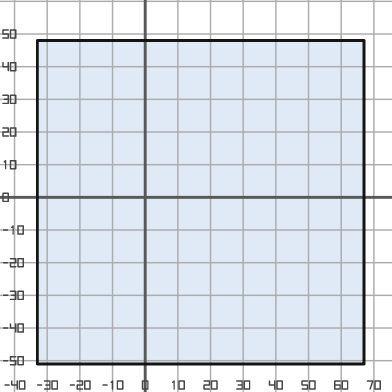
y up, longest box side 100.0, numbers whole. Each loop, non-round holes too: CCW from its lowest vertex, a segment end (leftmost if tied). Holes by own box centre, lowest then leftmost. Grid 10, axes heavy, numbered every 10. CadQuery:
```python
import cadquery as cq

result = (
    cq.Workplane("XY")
    .moveTo(-33.0, -51.0)
    .lineTo(67.0, -51.0)
    .lineTo(67.0, 48.0)
    .lineTo(-33.0, 48.0)
    .close()
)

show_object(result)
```